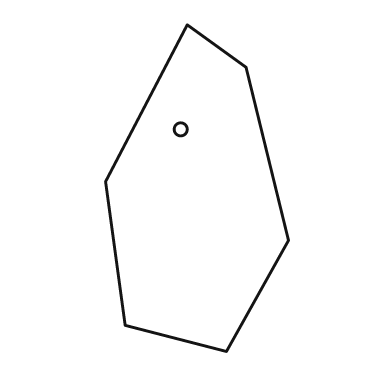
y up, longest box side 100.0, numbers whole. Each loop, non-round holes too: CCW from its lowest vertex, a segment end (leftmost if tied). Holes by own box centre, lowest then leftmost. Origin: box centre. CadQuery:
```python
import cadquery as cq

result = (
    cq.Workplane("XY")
    .moveTo(9.0, -50.0)
    .lineTo(28.0, -16.0)
    .lineTo(15.0, 37.0)
    .lineTo(-3.0, 50.0)
    .lineTo(-28.0, 2.0)
    .lineTo(-22.0, -42.0)
    .close()
    .moveTo(-5.0, 18.0)
    .circle(2.0)
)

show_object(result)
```